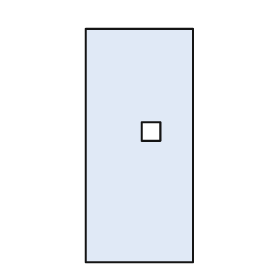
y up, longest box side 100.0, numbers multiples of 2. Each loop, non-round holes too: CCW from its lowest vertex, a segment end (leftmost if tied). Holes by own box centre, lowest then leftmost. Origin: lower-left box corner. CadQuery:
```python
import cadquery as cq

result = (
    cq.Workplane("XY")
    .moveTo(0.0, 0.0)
    .lineTo(46.0, 0.0)
    .lineTo(46.0, 100.0)
    .lineTo(0.0, 100.0)
    .close()
    .moveTo(24.0, 52.0)
    .lineTo(32.0, 52.0)
    .lineTo(32.0, 60.0)
    .lineTo(24.0, 60.0)
    .close()
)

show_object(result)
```